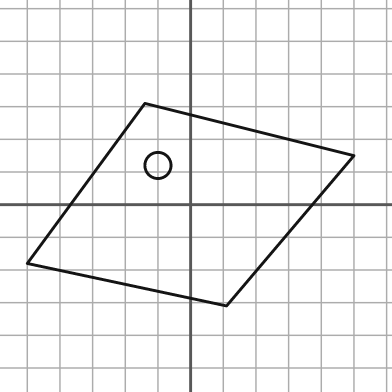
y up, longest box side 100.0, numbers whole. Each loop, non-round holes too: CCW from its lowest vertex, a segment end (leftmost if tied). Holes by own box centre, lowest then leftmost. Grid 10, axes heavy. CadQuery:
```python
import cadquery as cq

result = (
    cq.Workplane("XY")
    .moveTo(11.0, -31.0)
    .lineTo(50.0, 15.0)
    .lineTo(-14.0, 31.0)
    .lineTo(-50.0, -18.0)
    .close()
    .moveTo(-10.0, 12.0)
    .circle(4.0)
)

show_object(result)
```